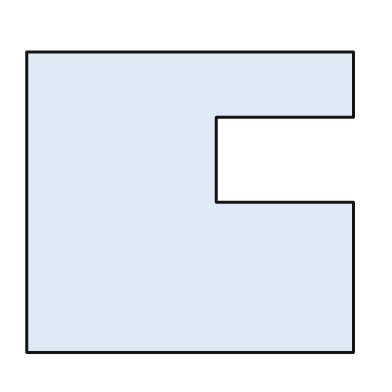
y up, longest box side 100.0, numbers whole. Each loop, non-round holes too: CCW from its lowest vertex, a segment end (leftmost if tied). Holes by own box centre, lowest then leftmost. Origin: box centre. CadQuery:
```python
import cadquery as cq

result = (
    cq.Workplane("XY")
    .moveTo(-50.0, -46.0)
    .lineTo(50.0, -46.0)
    .lineTo(50.0, 0.0)
    .lineTo(8.0, 0.0)
    .lineTo(8.0, 26.0)
    .lineTo(50.0, 26.0)
    .lineTo(50.0, 46.0)
    .lineTo(-50.0, 46.0)
    .close()
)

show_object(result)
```